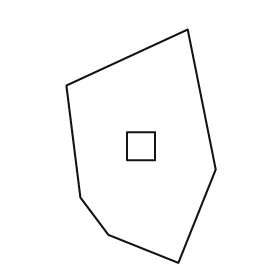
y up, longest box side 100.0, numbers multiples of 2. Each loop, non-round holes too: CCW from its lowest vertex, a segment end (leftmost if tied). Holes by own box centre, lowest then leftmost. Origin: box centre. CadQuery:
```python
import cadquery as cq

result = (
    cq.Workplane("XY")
    .moveTo(16.0, -50.0)
    .lineTo(32.0, -10.0)
    .lineTo(20.0, 50.0)
    .lineTo(-32.0, 26.0)
    .lineTo(-26.0, -22.0)
    .lineTo(-14.0, -38.0)
    .close()
    .moveTo(-6.0, -6.0)
    .lineTo(6.0, -6.0)
    .lineTo(6.0, 6.0)
    .lineTo(-6.0, 6.0)
    .close()
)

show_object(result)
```